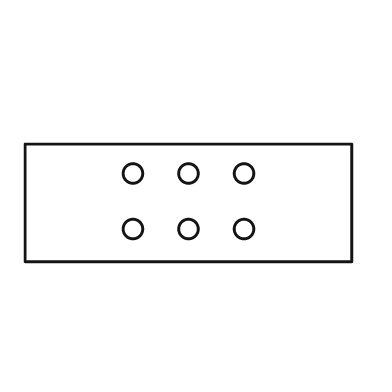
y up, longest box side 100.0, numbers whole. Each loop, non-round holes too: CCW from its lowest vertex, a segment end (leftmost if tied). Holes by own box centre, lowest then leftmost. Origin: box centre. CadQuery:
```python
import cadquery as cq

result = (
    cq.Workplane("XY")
    .moveTo(-50.0, -18.0)
    .lineTo(50.0, -18.0)
    .lineTo(50.0, 18.0)
    .lineTo(-50.0, 18.0)
    .close()
    .moveTo(-17.0, -8.0)
    .circle(3.0)
    .moveTo(0.0, -8.0)
    .circle(3.0)
    .moveTo(17.0, -8.0)
    .circle(3.0)
    .moveTo(-17.0, 9.0)
    .circle(3.0)
    .moveTo(0.0, 9.0)
    .circle(3.0)
    .moveTo(17.0, 9.0)
    .circle(3.0)
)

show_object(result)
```